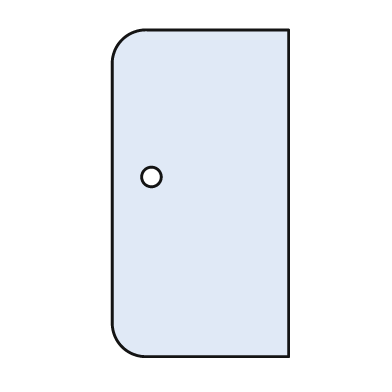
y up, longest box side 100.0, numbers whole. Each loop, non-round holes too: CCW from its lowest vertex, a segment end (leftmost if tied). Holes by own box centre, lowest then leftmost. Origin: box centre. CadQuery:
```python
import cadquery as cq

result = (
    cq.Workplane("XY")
    .moveTo(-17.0, -50.0)
    .lineTo(27.0, -50.0)
    .lineTo(27.0, 50.0)
    .lineTo(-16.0, 50.0)
    .threePointArc((-24.0, 47.0), (-27.0, 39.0))
    .lineTo(-27.0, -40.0)
    .threePointArc((-24.0, -47.0), (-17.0, -50.0))
    .close()
    .moveTo(-15.0, 5.0)
    .circle(3.0)
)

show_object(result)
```